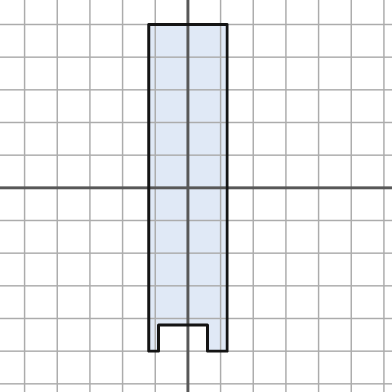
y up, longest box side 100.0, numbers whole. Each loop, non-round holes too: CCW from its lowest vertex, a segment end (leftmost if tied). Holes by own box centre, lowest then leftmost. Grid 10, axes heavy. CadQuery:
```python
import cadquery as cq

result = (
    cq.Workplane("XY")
    .moveTo(-12.0, -50.0)
    .lineTo(-9.0, -50.0)
    .lineTo(-9.0, -42.0)
    .lineTo(6.0, -42.0)
    .lineTo(6.0, -50.0)
    .lineTo(12.0, -50.0)
    .lineTo(12.0, 50.0)
    .lineTo(-12.0, 50.0)
    .close()
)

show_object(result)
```